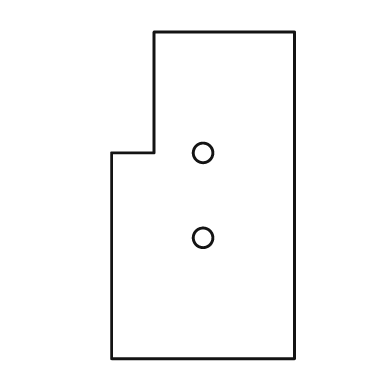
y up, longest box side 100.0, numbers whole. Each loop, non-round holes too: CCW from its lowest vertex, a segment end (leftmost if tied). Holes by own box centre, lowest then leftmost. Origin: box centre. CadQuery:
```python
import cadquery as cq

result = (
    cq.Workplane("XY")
    .moveTo(-28.0, -50.0)
    .lineTo(28.0, -50.0)
    .lineTo(28.0, 50.0)
    .lineTo(-15.0, 50.0)
    .lineTo(-15.0, 13.0)
    .lineTo(-28.0, 13.0)
    .close()
    .moveTo(0.0, -13.0)
    .circle(3.0)
    .moveTo(0.0, 13.0)
    .circle(3.0)
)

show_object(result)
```